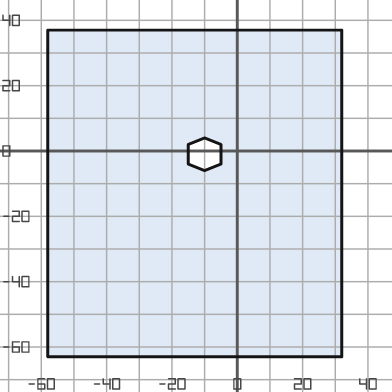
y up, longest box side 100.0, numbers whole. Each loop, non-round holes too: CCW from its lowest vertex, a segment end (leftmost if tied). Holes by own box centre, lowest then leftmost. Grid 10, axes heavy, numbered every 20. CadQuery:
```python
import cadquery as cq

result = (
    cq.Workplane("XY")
    .moveTo(-58.0, -63.0)
    .lineTo(32.0, -63.0)
    .lineTo(32.0, 37.0)
    .lineTo(-58.0, 37.0)
    .close()
    .moveTo(-10.0, -6.0)
    .lineTo(-5.0, -4.0)
    .lineTo(-5.0, 2.0)
    .lineTo(-10.0, 4.0)
    .lineTo(-15.0, 2.0)
    .lineTo(-15.0, -4.0)
    .close()
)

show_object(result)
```